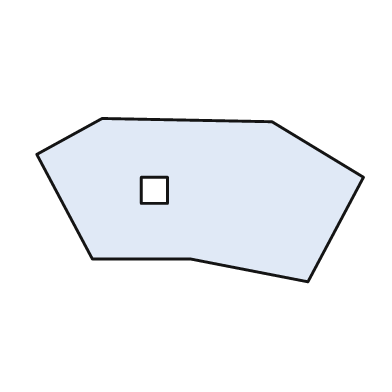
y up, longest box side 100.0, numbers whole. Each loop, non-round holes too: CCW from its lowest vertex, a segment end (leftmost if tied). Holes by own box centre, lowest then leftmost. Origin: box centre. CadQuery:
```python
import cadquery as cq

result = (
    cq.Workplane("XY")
    .moveTo(33.0, -25.0)
    .lineTo(50.0, 7.0)
    .lineTo(22.0, 24.0)
    .lineTo(-30.0, 25.0)
    .lineTo(-50.0, 14.0)
    .lineTo(-33.0, -18.0)
    .lineTo(-3.0, -18.0)
    .close()
    .moveTo(-18.0, -1.0)
    .lineTo(-10.0, -1.0)
    .lineTo(-10.0, 7.0)
    .lineTo(-18.0, 7.0)
    .close()
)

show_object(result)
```